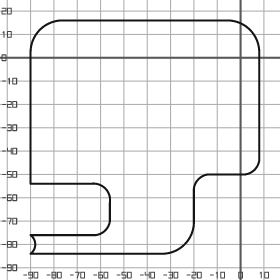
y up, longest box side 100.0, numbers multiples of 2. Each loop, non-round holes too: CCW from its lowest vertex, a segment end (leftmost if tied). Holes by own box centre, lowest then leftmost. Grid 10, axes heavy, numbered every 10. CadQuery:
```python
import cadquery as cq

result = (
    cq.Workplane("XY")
    .moveTo(-90.0, -84.0)
    .lineTo(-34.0, -84.0)
    .threePointArc((-24.0, -80.0), (-20.0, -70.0))
    .lineTo(-20.0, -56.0)
    .threePointArc((-18.0, -52.0), (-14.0, -50.0))
    .lineTo(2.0, -50.0)
    .threePointArc((6.0, -48.0), (8.0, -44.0))
    .lineTo(8.0, 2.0)
    .threePointArc((4.0, 12.0), (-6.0, 16.0))
    .lineTo(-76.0, 16.0)
    .threePointArc((-86.0, 12.0), (-90.0, 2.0))
    .lineTo(-90.0, -54.0)
    .lineTo(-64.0, -54.0)
    .threePointArc((-58.0, -56.0), (-56.0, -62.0))
    .lineTo(-56.0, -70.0)
    .threePointArc((-58.0, -74.0), (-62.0, -76.0))
    .lineTo(-90.0, -76.0)
    .threePointArc((-88.0, -80.0), (-90.0, -84.0))
    .close()
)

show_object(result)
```